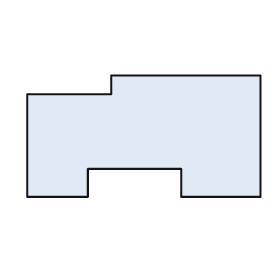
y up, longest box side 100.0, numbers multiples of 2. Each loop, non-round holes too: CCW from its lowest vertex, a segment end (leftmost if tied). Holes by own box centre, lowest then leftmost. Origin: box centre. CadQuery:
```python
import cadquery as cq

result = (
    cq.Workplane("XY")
    .moveTo(-50.0, -26.0)
    .lineTo(-24.0, -26.0)
    .lineTo(-24.0, -14.0)
    .lineTo(16.0, -14.0)
    .lineTo(16.0, -26.0)
    .lineTo(50.0, -26.0)
    .lineTo(50.0, 26.0)
    .lineTo(-14.0, 26.0)
    .lineTo(-14.0, 18.0)
    .lineTo(-50.0, 18.0)
    .close()
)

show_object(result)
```